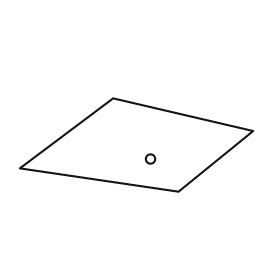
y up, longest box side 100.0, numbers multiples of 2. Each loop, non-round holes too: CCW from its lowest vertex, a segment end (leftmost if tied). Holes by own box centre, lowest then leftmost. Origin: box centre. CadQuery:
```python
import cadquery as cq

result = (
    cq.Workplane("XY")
    .moveTo(18.0, -20.0)
    .lineTo(50.0, 6.0)
    .lineTo(-10.0, 20.0)
    .lineTo(-50.0, -10.0)
    .close()
    .moveTo(6.0, -6.0)
    .circle(2.0)
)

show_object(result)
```